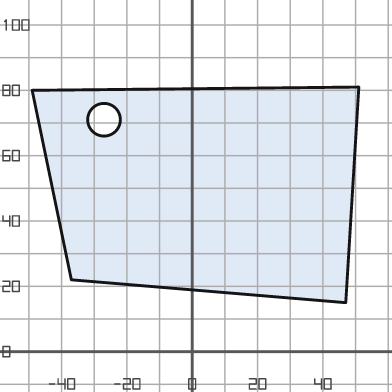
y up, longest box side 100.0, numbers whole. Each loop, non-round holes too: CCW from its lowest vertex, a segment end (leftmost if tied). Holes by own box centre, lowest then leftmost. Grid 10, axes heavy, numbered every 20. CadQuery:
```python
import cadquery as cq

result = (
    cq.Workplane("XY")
    .moveTo(47.0, 15.0)
    .lineTo(51.0, 81.0)
    .lineTo(-49.0, 80.0)
    .lineTo(-37.0, 22.0)
    .close()
    .moveTo(-27.0, 71.0)
    .circle(5.0)
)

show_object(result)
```